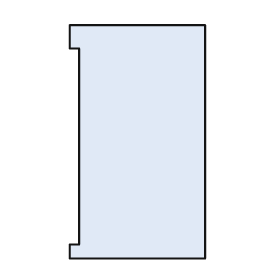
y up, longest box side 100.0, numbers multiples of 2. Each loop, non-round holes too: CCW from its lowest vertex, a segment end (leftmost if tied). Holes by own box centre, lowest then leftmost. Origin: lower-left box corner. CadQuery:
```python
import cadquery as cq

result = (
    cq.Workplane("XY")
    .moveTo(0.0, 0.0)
    .lineTo(58.0, 0.0)
    .lineTo(58.0, 100.0)
    .lineTo(0.0, 100.0)
    .lineTo(0.0, 90.0)
    .lineTo(4.0, 90.0)
    .lineTo(4.0, 6.0)
    .lineTo(0.0, 6.0)
    .close()
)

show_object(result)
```